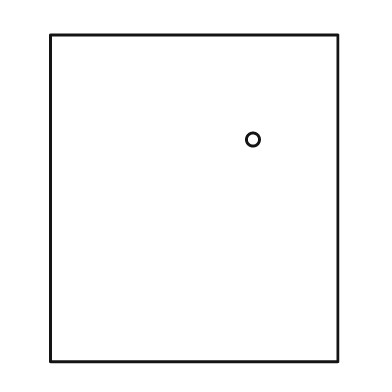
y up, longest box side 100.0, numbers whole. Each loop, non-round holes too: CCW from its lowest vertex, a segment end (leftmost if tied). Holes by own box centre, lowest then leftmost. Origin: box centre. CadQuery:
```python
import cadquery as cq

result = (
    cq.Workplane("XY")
    .moveTo(-44.0, -50.0)
    .lineTo(44.0, -50.0)
    .lineTo(44.0, 50.0)
    .lineTo(-44.0, 50.0)
    .close()
    .moveTo(18.0, 18.0)
    .circle(2.0)
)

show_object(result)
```